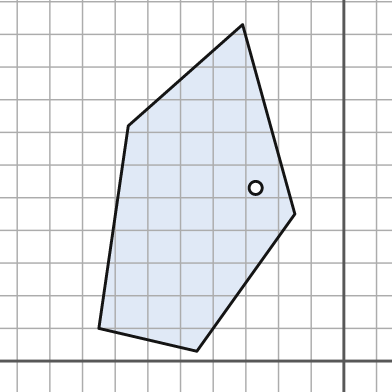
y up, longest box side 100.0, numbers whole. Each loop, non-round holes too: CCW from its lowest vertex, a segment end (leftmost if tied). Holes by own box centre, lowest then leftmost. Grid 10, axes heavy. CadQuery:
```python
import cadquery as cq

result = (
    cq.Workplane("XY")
    .moveTo(-45.0, 3.0)
    .lineTo(-15.0, 45.0)
    .lineTo(-31.0, 103.0)
    .lineTo(-66.0, 72.0)
    .lineTo(-75.0, 10.0)
    .close()
    .moveTo(-27.0, 53.0)
    .circle(2.0)
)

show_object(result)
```